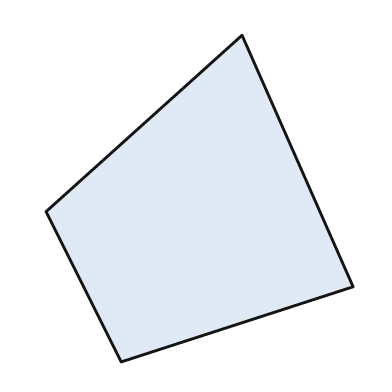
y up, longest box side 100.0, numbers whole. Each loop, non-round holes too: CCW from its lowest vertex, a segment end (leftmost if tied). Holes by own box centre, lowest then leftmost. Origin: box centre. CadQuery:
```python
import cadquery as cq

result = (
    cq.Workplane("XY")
    .moveTo(-24.0, -50.0)
    .lineTo(47.0, -27.0)
    .lineTo(13.0, 50.0)
    .lineTo(-47.0, -4.0)
    .close()
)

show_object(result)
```